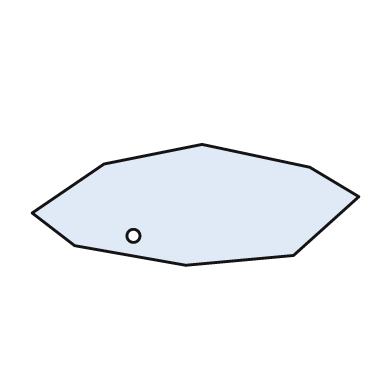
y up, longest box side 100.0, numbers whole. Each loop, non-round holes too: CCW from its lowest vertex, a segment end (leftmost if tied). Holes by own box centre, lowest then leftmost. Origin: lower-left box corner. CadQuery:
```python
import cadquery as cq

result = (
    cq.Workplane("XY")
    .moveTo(47.0, 0.0)
    .lineTo(80.0, 3.0)
    .lineTo(100.0, 21.0)
    .lineTo(85.0, 30.0)
    .lineTo(52.0, 37.0)
    .lineTo(22.0, 31.0)
    .lineTo(0.0, 16.0)
    .lineTo(13.0, 6.0)
    .close()
    .moveTo(31.0, 9.0)
    .circle(2.0)
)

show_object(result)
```